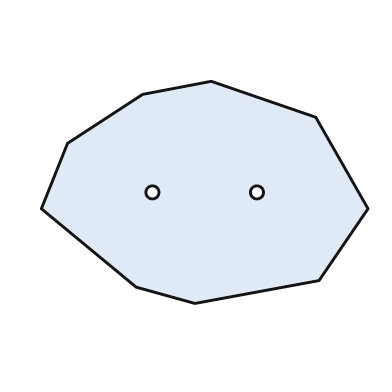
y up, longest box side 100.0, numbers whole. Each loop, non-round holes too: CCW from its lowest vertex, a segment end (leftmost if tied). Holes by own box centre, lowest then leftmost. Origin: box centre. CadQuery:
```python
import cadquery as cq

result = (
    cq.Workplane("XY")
    .moveTo(-3.0, -34.0)
    .lineTo(35.0, -27.0)
    .lineTo(50.0, -5.0)
    .lineTo(34.0, 23.0)
    .lineTo(2.0, 34.0)
    .lineTo(-19.0, 30.0)
    .lineTo(-42.0, 15.0)
    .lineTo(-50.0, -5.0)
    .lineTo(-21.0, -29.0)
    .close()
    .moveTo(-16.0, 0.0)
    .circle(2.0)
    .moveTo(16.0, 0.0)
    .circle(2.0)
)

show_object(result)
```